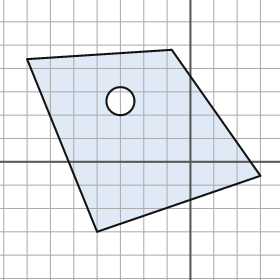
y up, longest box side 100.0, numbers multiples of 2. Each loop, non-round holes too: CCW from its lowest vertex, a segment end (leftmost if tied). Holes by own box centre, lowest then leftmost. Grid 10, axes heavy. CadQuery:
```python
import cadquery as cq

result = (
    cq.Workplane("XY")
    .moveTo(-40.0, -30.0)
    .lineTo(30.0, -6.0)
    .lineTo(-8.0, 48.0)
    .lineTo(-70.0, 44.0)
    .close()
    .moveTo(-30.0, 26.0)
    .circle(6.0)
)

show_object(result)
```